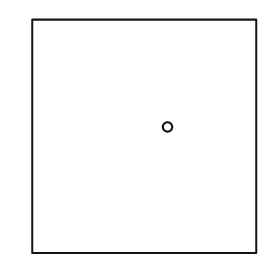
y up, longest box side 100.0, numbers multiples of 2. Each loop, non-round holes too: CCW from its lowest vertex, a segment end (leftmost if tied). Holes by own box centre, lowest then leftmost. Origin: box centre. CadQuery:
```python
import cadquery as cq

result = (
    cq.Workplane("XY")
    .moveTo(-48.0, -50.0)
    .lineTo(48.0, -50.0)
    .lineTo(48.0, 50.0)
    .lineTo(-48.0, 50.0)
    .close()
    .moveTo(10.0, 4.0)
    .circle(2.0)
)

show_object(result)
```